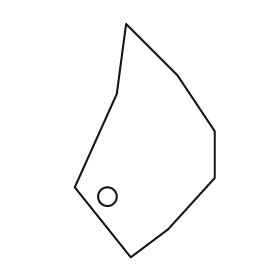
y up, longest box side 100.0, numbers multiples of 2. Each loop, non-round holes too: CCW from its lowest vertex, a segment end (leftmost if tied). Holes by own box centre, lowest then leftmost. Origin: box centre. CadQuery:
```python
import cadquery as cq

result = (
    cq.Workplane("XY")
    .moveTo(-6.0, -50.0)
    .lineTo(10.0, -38.0)
    .lineTo(30.0, -16.0)
    .lineTo(30.0, 4.0)
    .lineTo(14.0, 28.0)
    .lineTo(-8.0, 50.0)
    .lineTo(-12.0, 20.0)
    .lineTo(-30.0, -20.0)
    .close()
    .moveTo(-16.0, -24.0)
    .circle(4.0)
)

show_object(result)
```